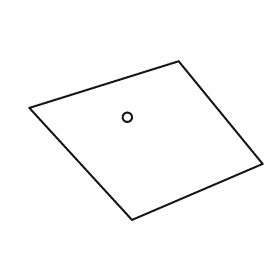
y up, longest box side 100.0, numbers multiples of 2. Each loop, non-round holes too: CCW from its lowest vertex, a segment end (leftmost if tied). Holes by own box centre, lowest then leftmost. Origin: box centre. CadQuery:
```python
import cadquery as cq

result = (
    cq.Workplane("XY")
    .moveTo(-6.0, -34.0)
    .lineTo(50.0, -10.0)
    .lineTo(14.0, 34.0)
    .lineTo(-50.0, 14.0)
    .close()
    .moveTo(-8.0, 10.0)
    .circle(2.0)
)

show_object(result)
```